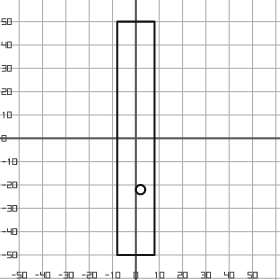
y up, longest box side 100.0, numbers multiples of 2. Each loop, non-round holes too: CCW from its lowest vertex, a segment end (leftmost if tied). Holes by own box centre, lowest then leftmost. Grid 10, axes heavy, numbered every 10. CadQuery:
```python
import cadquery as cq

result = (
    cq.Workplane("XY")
    .moveTo(-8.0, -50.0)
    .lineTo(8.0, -50.0)
    .lineTo(8.0, 50.0)
    .lineTo(-8.0, 50.0)
    .close()
    .moveTo(2.0, -22.0)
    .circle(2.0)
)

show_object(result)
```